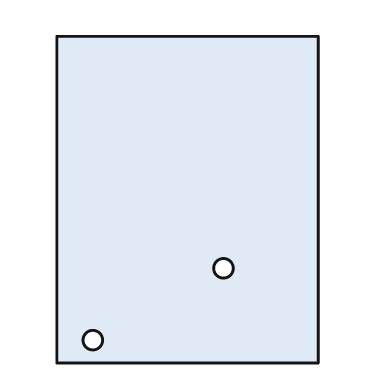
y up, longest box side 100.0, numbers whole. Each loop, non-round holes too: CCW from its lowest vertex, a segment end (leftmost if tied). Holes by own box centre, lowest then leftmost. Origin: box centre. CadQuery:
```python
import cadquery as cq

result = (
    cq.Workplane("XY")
    .moveTo(-40.0, -50.0)
    .lineTo(40.0, -50.0)
    .lineTo(40.0, 50.0)
    .lineTo(-40.0, 50.0)
    .close()
    .moveTo(-29.0, -43.0)
    .circle(3.0)
    .moveTo(11.0, -21.0)
    .circle(3.0)
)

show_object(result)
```